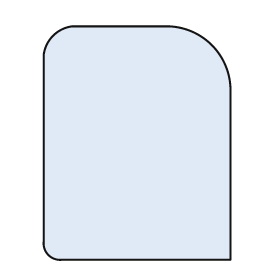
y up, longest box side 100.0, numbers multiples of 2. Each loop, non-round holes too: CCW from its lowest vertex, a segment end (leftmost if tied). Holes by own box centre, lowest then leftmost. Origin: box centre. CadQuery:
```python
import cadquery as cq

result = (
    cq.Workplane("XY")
    .moveTo(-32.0, -50.0)
    .lineTo(40.0, -50.0)
    .lineTo(40.0, 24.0)
    .threePointArc((32.0, 42.0), (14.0, 50.0))
    .lineTo(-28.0, 50.0)
    .threePointArc((-36.0, 46.0), (-40.0, 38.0))
    .lineTo(-40.0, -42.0)
    .threePointArc((-38.0, -48.0), (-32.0, -50.0))
    .close()
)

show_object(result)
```